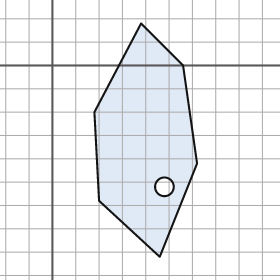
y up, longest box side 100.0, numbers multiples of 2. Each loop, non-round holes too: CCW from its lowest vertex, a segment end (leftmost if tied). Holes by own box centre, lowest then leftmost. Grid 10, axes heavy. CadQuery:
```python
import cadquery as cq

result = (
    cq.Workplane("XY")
    .moveTo(46.0, -82.0)
    .lineTo(62.0, -42.0)
    .lineTo(56.0, 0.0)
    .lineTo(38.0, 18.0)
    .lineTo(18.0, -20.0)
    .lineTo(20.0, -58.0)
    .close()
    .moveTo(48.0, -52.0)
    .circle(4.0)
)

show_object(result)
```